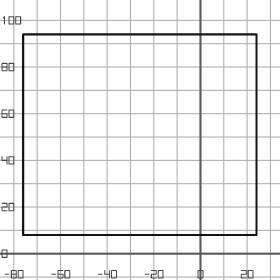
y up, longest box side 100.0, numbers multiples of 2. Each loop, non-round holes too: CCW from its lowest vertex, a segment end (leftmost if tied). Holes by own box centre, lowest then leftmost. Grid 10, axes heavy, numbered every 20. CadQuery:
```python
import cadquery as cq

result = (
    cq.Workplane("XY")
    .moveTo(-76.0, 8.0)
    .lineTo(24.0, 8.0)
    .lineTo(24.0, 94.0)
    .lineTo(-76.0, 94.0)
    .close()
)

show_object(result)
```